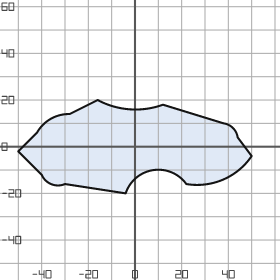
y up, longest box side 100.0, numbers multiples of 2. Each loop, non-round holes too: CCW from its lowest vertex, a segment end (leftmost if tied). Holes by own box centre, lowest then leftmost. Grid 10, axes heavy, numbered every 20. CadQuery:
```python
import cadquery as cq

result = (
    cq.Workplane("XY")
    .moveTo(-4.0, -20.0)
    .threePointArc((8.0, -10.0), (22.0, -16.0))
    .threePointArc((38.0, -14.0), (50.0, -4.0))
    .lineTo(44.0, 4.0)
    .threePointArc((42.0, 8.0), (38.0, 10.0))
    .lineTo(12.0, 18.0)
    .threePointArc((-2.0, 16.0), (-16.0, 20.0))
    .lineTo(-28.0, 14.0)
    .threePointArc((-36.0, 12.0), (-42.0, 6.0))
    .lineTo(-50.0, -2.0)
    .lineTo(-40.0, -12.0)
    .threePointArc((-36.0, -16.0), (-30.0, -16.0))
    .close()
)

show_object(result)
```